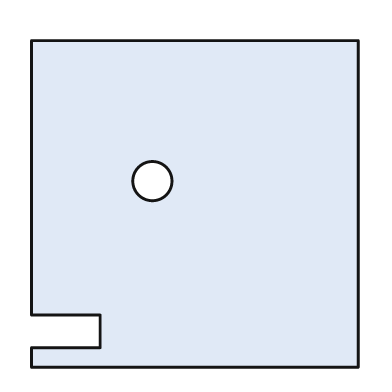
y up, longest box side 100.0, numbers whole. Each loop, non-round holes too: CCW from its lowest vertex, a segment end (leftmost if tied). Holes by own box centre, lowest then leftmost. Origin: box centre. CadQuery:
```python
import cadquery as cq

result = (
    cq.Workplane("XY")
    .moveTo(-50.0, -50.0)
    .lineTo(50.0, -50.0)
    .lineTo(50.0, 50.0)
    .lineTo(-50.0, 50.0)
    .lineTo(-50.0, -34.0)
    .lineTo(-29.0, -34.0)
    .lineTo(-29.0, -44.0)
    .lineTo(-50.0, -44.0)
    .close()
    .moveTo(-13.0, 7.0)
    .circle(6.0)
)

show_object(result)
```